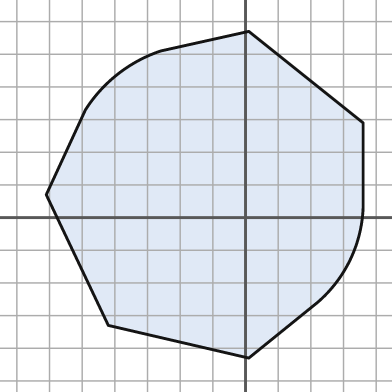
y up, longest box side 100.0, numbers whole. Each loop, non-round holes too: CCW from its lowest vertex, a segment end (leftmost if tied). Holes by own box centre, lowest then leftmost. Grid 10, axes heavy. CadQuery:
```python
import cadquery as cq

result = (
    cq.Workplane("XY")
    .moveTo(1.0, -43.0)
    .lineTo(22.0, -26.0)
    .threePointArc((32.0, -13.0), (36.0, 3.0))
    .lineTo(36.0, 29.0)
    .lineTo(1.0, 57.0)
    .lineTo(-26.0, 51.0)
    .threePointArc((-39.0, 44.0), (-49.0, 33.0))
    .lineTo(-61.0, 7.0)
    .lineTo(-42.0, -33.0)
    .close()
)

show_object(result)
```